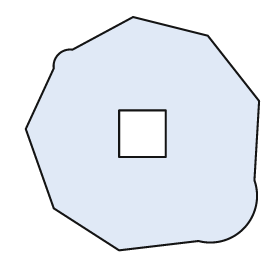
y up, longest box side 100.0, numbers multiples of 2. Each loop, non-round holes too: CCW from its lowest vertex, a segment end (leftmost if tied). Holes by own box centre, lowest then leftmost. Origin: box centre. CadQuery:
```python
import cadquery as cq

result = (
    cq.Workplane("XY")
    .moveTo(-10.0, -50.0)
    .lineTo(24.0, -46.0)
    .threePointArc((44.0, -40.0), (48.0, -20.0))
    .lineTo(50.0, 14.0)
    .lineTo(28.0, 42.0)
    .lineTo(-4.0, 50.0)
    .lineTo(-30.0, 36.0)
    .threePointArc((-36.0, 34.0), (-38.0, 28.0))
    .lineTo(-50.0, 2.0)
    .lineTo(-38.0, -32.0)
    .close()
    .moveTo(-10.0, -10.0)
    .lineTo(10.0, -10.0)
    .lineTo(10.0, 10.0)
    .lineTo(-10.0, 10.0)
    .close()
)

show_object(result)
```